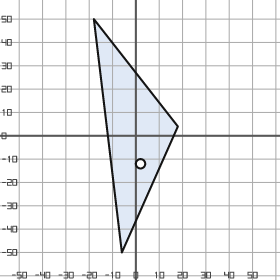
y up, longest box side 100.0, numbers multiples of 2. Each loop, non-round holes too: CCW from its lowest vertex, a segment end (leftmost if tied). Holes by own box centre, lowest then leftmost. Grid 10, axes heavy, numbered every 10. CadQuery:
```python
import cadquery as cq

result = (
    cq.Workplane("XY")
    .moveTo(-6.0, -50.0)
    .lineTo(18.0, 4.0)
    .lineTo(-18.0, 50.0)
    .close()
    .moveTo(2.0, -12.0)
    .circle(2.0)
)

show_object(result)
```